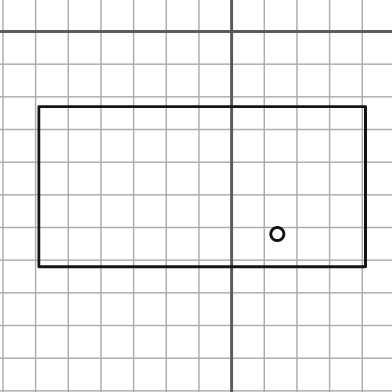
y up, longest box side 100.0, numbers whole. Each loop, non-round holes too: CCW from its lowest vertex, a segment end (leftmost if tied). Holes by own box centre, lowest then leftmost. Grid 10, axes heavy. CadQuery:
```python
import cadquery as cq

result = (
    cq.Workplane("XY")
    .moveTo(-59.0, -72.0)
    .lineTo(41.0, -72.0)
    .lineTo(41.0, -23.0)
    .lineTo(-59.0, -23.0)
    .close()
    .moveTo(14.0, -62.0)
    .circle(2.0)
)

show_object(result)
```